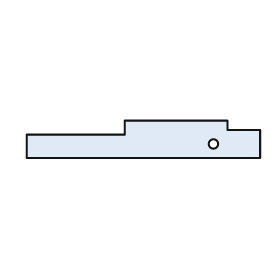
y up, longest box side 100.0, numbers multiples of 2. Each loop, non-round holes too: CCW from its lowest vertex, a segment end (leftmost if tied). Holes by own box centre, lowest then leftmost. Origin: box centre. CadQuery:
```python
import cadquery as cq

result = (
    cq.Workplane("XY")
    .moveTo(-50.0, -8.0)
    .lineTo(50.0, -8.0)
    .lineTo(50.0, 4.0)
    .lineTo(36.0, 4.0)
    .lineTo(36.0, 8.0)
    .lineTo(-8.0, 8.0)
    .lineTo(-8.0, 2.0)
    .lineTo(-50.0, 2.0)
    .close()
    .moveTo(30.0, -2.0)
    .circle(2.0)
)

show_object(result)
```